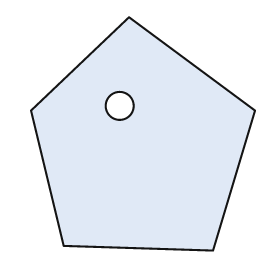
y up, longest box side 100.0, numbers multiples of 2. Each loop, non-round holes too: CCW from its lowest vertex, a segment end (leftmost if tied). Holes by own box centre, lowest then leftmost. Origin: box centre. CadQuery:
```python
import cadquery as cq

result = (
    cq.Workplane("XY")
    .moveTo(30.0, -50.0)
    .lineTo(48.0, 10.0)
    .lineTo(-6.0, 50.0)
    .lineTo(-48.0, 10.0)
    .lineTo(-34.0, -48.0)
    .close()
    .moveTo(-10.0, 12.0)
    .circle(6.0)
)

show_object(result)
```